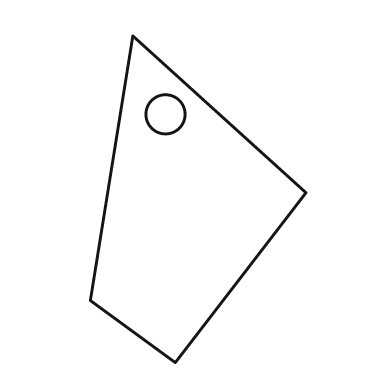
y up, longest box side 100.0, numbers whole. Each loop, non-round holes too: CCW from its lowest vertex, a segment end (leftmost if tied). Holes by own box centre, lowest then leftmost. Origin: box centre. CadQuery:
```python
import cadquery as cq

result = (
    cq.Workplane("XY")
    .moveTo(-7.0, -50.0)
    .lineTo(33.0, 2.0)
    .lineTo(-20.0, 50.0)
    .lineTo(-33.0, -31.0)
    .close()
    .moveTo(-10.0, 26.0)
    .circle(6.0)
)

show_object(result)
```